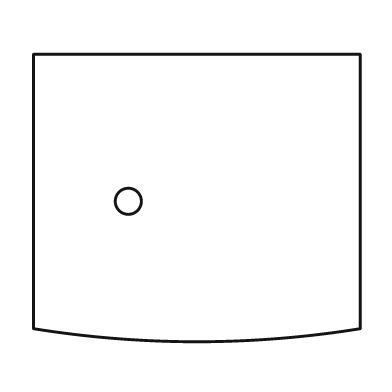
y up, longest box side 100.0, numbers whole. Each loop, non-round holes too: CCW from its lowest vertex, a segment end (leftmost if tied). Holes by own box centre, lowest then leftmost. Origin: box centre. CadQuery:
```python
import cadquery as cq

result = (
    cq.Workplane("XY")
    .moveTo(-50.0, -40.0)
    .threePointArc((0.0, -44.0), (50.0, -40.0))
    .lineTo(50.0, 44.0)
    .lineTo(-50.0, 44.0)
    .close()
    .moveTo(-21.0, -1.0)
    .circle(4.0)
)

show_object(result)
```